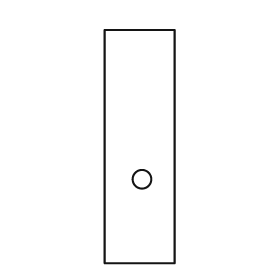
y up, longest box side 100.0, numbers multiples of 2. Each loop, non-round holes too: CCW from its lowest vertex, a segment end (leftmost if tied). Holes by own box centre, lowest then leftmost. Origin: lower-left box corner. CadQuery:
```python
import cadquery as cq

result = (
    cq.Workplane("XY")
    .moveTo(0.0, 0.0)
    .lineTo(30.0, 0.0)
    .lineTo(30.0, 100.0)
    .lineTo(0.0, 100.0)
    .close()
    .moveTo(16.0, 36.0)
    .circle(4.0)
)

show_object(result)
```